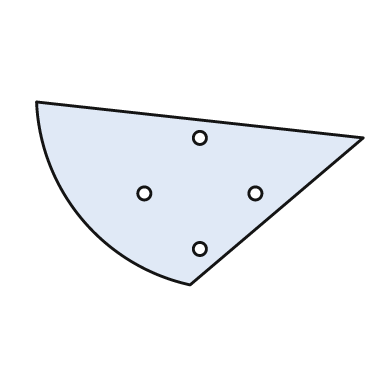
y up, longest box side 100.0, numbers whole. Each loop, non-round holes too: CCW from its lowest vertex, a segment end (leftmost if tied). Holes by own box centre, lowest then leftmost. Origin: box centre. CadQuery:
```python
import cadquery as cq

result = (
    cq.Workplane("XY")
    .moveTo(-3.0, -28.0)
    .lineTo(50.0, 17.0)
    .lineTo(-50.0, 28.0)
    .threePointArc((-36.0, -8.0), (-3.0, -28.0))
    .close()
    .moveTo(0.0, -17.0)
    .circle(2.0)
    .moveTo(-17.0, 0.0)
    .circle(2.0)
    .moveTo(17.0, 0.0)
    .circle(2.0)
    .moveTo(0.0, 17.0)
    .circle(2.0)
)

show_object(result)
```